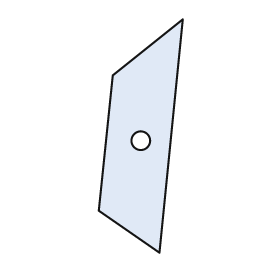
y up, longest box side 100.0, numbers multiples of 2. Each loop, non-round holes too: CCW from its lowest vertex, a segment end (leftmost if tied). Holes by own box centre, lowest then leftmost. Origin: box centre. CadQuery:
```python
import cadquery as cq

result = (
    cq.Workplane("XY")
    .moveTo(8.0, -50.0)
    .lineTo(18.0, 50.0)
    .lineTo(-12.0, 26.0)
    .lineTo(-18.0, -32.0)
    .close()
    .moveTo(0.0, -2.0)
    .circle(4.0)
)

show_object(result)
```